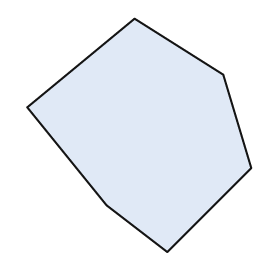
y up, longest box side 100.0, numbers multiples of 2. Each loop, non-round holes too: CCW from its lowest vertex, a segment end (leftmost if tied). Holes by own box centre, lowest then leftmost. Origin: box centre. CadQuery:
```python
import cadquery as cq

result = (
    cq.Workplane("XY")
    .moveTo(12.0, -50.0)
    .lineTo(48.0, -14.0)
    .lineTo(36.0, 26.0)
    .lineTo(-2.0, 50.0)
    .lineTo(-48.0, 12.0)
    .lineTo(-14.0, -30.0)
    .close()
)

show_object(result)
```